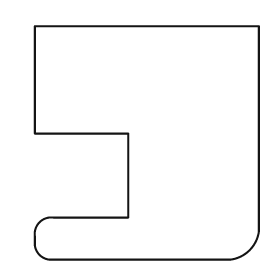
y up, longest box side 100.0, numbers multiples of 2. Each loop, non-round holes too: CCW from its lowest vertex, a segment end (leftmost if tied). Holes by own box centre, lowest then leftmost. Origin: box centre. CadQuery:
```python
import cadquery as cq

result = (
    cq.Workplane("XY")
    .moveTo(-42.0, -50.0)
    .lineTo(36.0, -50.0)
    .threePointArc((44.0, -46.0), (48.0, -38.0))
    .lineTo(48.0, 50.0)
    .lineTo(-48.0, 50.0)
    .lineTo(-48.0, 4.0)
    .lineTo(-8.0, 4.0)
    .lineTo(-8.0, -32.0)
    .lineTo(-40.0, -32.0)
    .threePointArc((-46.0, -34.0), (-48.0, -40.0))
    .lineTo(-48.0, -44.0)
    .threePointArc((-46.0, -48.0), (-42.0, -50.0))
    .close()
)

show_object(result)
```